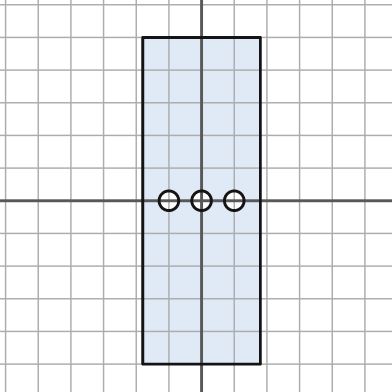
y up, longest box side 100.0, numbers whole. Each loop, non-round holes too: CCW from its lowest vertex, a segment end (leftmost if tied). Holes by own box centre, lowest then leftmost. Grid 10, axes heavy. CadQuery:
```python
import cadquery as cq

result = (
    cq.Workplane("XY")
    .moveTo(-18.0, -50.0)
    .lineTo(18.0, -50.0)
    .lineTo(18.0, 50.0)
    .lineTo(-18.0, 50.0)
    .close()
    .moveTo(-10.0, 0.0)
    .circle(3.0)
    .moveTo(0.0, 0.0)
    .circle(3.0)
    .moveTo(10.0, 0.0)
    .circle(3.0)
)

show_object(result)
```